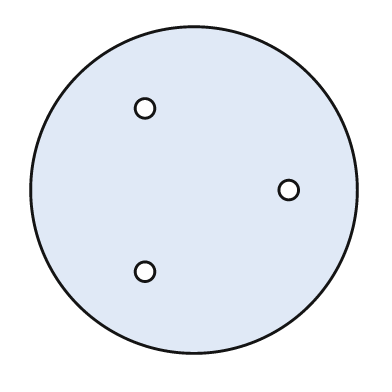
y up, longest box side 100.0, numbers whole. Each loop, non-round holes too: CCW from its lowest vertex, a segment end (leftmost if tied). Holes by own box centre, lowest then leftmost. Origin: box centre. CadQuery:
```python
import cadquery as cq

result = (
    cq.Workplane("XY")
    .moveTo(0.0, 0.0)
    .circle(50.0)
    .moveTo(-15.0, -25.0)
    .circle(3.0)
    .moveTo(29.0, 0.0)
    .circle(3.0)
    .moveTo(-15.0, 25.0)
    .circle(3.0)
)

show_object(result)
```